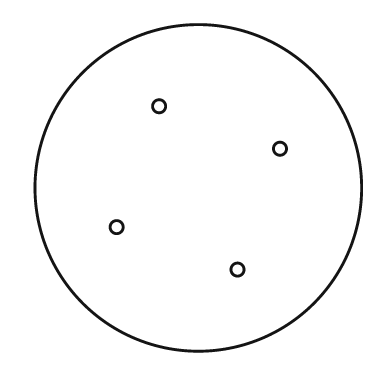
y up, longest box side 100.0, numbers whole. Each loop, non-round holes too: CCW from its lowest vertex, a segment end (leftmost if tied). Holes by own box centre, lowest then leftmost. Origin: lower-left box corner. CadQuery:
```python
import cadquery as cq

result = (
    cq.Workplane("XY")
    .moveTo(50.0, 50.0)
    .circle(50.0)
    .moveTo(62.0, 25.0)
    .circle(2.0)
    .moveTo(25.0, 38.0)
    .circle(2.0)
    .moveTo(75.0, 62.0)
    .circle(2.0)
    .moveTo(38.0, 75.0)
    .circle(2.0)
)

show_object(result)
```